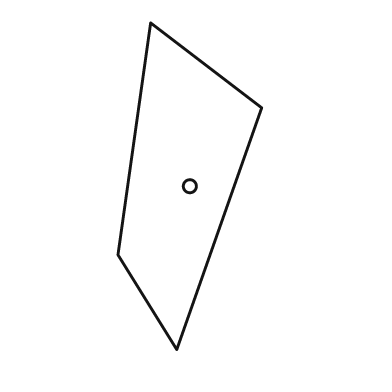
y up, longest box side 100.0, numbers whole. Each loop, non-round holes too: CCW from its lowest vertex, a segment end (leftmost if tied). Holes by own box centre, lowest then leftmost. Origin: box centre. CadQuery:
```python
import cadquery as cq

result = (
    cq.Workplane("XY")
    .moveTo(-4.0, -50.0)
    .lineTo(22.0, 24.0)
    .lineTo(-12.0, 50.0)
    .lineTo(-22.0, -21.0)
    .close()
    .moveTo(0.0, 0.0)
    .circle(2.0)
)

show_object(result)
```